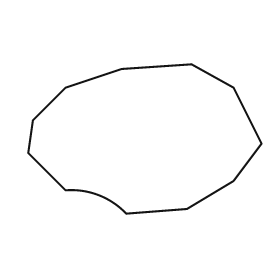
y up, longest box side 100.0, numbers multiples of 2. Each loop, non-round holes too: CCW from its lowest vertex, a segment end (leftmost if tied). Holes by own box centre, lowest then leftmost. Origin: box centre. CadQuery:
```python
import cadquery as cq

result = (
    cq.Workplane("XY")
    .moveTo(-8.0, -32.0)
    .lineTo(18.0, -30.0)
    .lineTo(38.0, -18.0)
    .lineTo(50.0, -2.0)
    .lineTo(38.0, 22.0)
    .lineTo(20.0, 32.0)
    .lineTo(-10.0, 30.0)
    .lineTo(-34.0, 22.0)
    .lineTo(-48.0, 8.0)
    .lineTo(-50.0, -6.0)
    .lineTo(-34.0, -22.0)
    .threePointArc((-20.0, -24.0), (-8.0, -32.0))
    .close()
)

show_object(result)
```